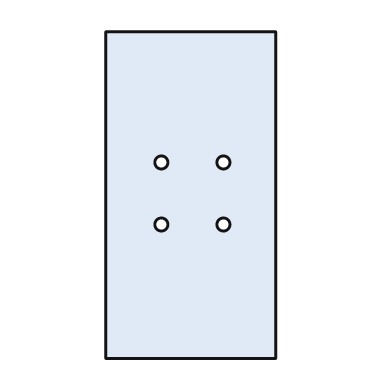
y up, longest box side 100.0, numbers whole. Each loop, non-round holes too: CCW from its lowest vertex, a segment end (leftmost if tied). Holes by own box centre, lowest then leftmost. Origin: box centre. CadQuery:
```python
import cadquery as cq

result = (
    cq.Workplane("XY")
    .moveTo(-26.0, -50.0)
    .lineTo(26.0, -50.0)
    .lineTo(26.0, 50.0)
    .lineTo(-26.0, 50.0)
    .close()
    .moveTo(-9.0, -9.0)
    .circle(2.0)
    .moveTo(10.0, -9.0)
    .circle(2.0)
    .moveTo(-9.0, 10.0)
    .circle(2.0)
    .moveTo(10.0, 10.0)
    .circle(2.0)
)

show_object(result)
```